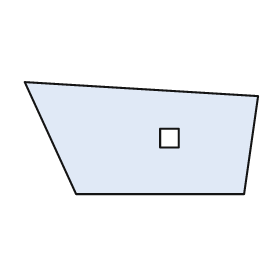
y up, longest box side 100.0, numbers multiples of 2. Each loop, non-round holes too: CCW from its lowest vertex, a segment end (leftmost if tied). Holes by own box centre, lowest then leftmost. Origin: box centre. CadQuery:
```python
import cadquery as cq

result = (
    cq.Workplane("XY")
    .moveTo(-28.0, -24.0)
    .lineTo(44.0, -24.0)
    .lineTo(50.0, 18.0)
    .lineTo(-50.0, 24.0)
    .close()
    .moveTo(8.0, -4.0)
    .lineTo(16.0, -4.0)
    .lineTo(16.0, 4.0)
    .lineTo(8.0, 4.0)
    .close()
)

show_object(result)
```